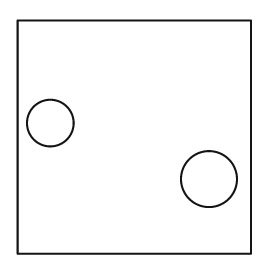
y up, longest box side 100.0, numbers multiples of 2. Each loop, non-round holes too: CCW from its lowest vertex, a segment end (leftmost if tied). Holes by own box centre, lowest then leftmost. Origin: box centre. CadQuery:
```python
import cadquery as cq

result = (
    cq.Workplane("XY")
    .moveTo(-50.0, -50.0)
    .lineTo(50.0, -50.0)
    .lineTo(50.0, 50.0)
    .lineTo(-50.0, 50.0)
    .close()
    .moveTo(32.0, -18.0)
    .circle(12.0)
    .moveTo(-36.0, 6.0)
    .circle(10.0)
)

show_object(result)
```